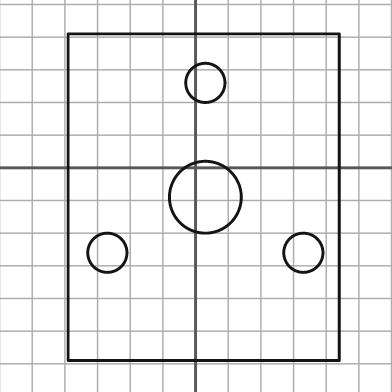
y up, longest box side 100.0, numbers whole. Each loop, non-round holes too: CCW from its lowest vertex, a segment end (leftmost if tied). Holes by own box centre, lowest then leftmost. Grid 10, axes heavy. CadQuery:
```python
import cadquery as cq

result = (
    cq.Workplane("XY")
    .moveTo(-39.0, -59.0)
    .lineTo(44.0, -59.0)
    .lineTo(44.0, 41.0)
    .lineTo(-39.0, 41.0)
    .close()
    .moveTo(-27.0, -26.0)
    .circle(6.0)
    .moveTo(33.0, -26.0)
    .circle(6.0)
    .moveTo(3.0, -9.0)
    .circle(11.0)
    .moveTo(3.0, 26.0)
    .circle(6.0)
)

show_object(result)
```